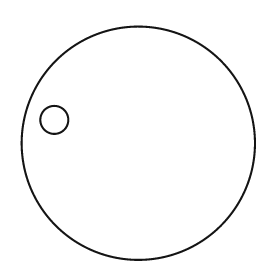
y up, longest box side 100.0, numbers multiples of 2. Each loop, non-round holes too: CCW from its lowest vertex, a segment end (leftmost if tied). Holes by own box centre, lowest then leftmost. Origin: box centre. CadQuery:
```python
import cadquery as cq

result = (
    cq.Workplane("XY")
    .moveTo(0.0, 0.0)
    .circle(50.0)
    .moveTo(-36.0, 10.0)
    .circle(6.0)
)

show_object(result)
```